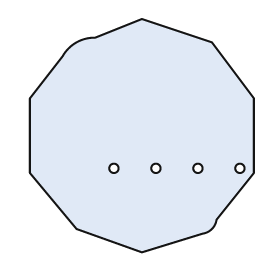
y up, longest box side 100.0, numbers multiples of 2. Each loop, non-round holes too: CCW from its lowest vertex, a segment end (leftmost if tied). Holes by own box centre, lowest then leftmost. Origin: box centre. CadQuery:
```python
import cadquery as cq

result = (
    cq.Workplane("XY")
    .moveTo(0.0, -50.0)
    .lineTo(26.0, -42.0)
    .threePointArc((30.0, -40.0), (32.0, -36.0))
    .lineTo(48.0, -16.0)
    .lineTo(48.0, 16.0)
    .lineTo(30.0, 40.0)
    .lineTo(0.0, 50.0)
    .lineTo(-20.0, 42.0)
    .threePointArc((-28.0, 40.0), (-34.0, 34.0))
    .lineTo(-48.0, 16.0)
    .lineTo(-48.0, -16.0)
    .lineTo(-28.0, -40.0)
    .close()
    .moveTo(-12.0, -14.0)
    .circle(2.0)
    .moveTo(6.0, -14.0)
    .circle(2.0)
    .moveTo(24.0, -14.0)
    .circle(2.0)
    .moveTo(42.0, -14.0)
    .circle(2.0)
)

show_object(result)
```